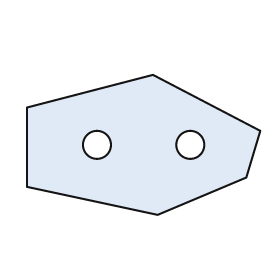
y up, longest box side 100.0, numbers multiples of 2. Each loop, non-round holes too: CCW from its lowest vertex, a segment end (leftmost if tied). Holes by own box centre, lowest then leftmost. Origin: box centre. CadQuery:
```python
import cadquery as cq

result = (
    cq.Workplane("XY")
    .moveTo(6.0, -30.0)
    .lineTo(44.0, -14.0)
    .lineTo(50.0, 6.0)
    .lineTo(4.0, 30.0)
    .lineTo(-50.0, 16.0)
    .lineTo(-50.0, -18.0)
    .close()
    .moveTo(-20.0, 0.0)
    .circle(6.0)
    .moveTo(20.0, 0.0)
    .circle(6.0)
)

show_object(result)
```